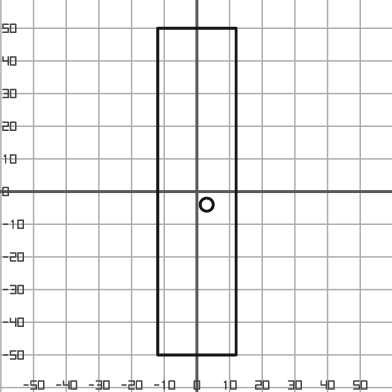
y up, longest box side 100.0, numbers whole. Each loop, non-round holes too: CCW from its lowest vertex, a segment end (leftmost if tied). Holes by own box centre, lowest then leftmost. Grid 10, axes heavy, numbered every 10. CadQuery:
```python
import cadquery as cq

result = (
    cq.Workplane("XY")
    .moveTo(-12.0, -50.0)
    .lineTo(12.0, -50.0)
    .lineTo(12.0, 50.0)
    .lineTo(-12.0, 50.0)
    .close()
    .moveTo(3.0, -4.0)
    .circle(2.0)
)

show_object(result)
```